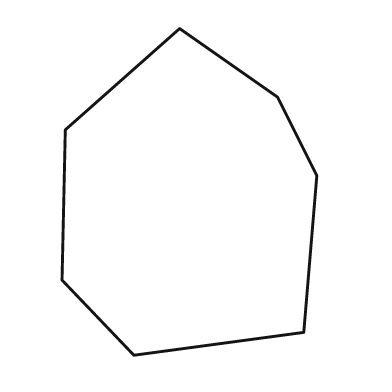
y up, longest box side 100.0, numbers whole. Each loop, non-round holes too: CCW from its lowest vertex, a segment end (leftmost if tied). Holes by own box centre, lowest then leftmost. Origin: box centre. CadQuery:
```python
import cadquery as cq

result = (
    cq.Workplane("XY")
    .moveTo(-17.0, -50.0)
    .lineTo(35.0, -43.0)
    .lineTo(39.0, 5.0)
    .lineTo(27.0, 29.0)
    .lineTo(-3.0, 50.0)
    .lineTo(-38.0, 19.0)
    .lineTo(-39.0, -27.0)
    .close()
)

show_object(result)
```